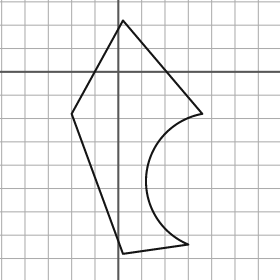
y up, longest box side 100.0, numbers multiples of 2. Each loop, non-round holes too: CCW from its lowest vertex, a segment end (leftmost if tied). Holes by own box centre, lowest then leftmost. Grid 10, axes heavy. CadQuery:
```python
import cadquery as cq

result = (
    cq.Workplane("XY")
    .moveTo(2.0, -78.0)
    .lineTo(30.0, -74.0)
    .threePointArc((12.0, -44.0), (36.0, -18.0))
    .lineTo(2.0, 22.0)
    .lineTo(-20.0, -18.0)
    .close()
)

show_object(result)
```